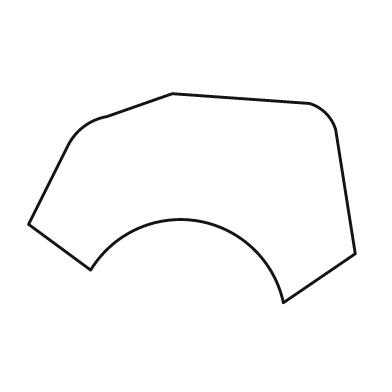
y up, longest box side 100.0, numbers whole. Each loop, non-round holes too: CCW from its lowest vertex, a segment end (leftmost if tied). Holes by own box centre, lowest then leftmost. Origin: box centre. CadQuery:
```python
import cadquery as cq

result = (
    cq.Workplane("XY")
    .moveTo(28.0, -32.0)
    .lineTo(50.0, -17.0)
    .lineTo(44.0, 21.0)
    .threePointArc((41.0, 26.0), (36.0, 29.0))
    .lineTo(-6.0, 32.0)
    .lineTo(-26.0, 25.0)
    .threePointArc((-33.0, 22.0), (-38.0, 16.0))
    .lineTo(-50.0, -8.0)
    .lineTo(-31.0, -22.0)
    .threePointArc((2.0, -7.0), (28.0, -32.0))
    .close()
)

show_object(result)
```